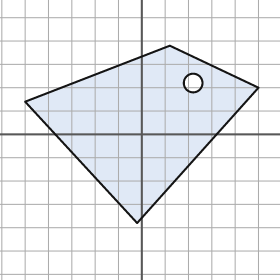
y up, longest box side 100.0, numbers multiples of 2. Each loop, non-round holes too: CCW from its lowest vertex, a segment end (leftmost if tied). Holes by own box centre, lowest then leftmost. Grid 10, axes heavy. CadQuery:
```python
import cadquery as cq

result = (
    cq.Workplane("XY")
    .moveTo(-2.0, -38.0)
    .lineTo(50.0, 20.0)
    .lineTo(12.0, 38.0)
    .lineTo(-50.0, 14.0)
    .close()
    .moveTo(22.0, 22.0)
    .circle(4.0)
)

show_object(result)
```